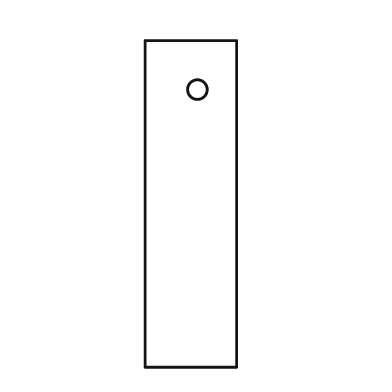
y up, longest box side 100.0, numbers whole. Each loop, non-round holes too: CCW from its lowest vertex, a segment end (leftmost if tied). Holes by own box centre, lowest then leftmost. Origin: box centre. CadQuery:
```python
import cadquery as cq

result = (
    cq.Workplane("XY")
    .moveTo(-14.0, -50.0)
    .lineTo(14.0, -50.0)
    .lineTo(14.0, 50.0)
    .lineTo(-14.0, 50.0)
    .close()
    .moveTo(2.0, 35.0)
    .circle(3.0)
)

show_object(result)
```